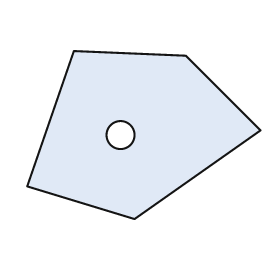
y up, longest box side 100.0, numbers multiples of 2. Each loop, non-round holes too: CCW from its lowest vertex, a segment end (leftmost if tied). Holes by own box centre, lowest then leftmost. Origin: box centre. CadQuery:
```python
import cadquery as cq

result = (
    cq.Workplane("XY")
    .moveTo(-4.0, -36.0)
    .lineTo(50.0, 2.0)
    .lineTo(18.0, 34.0)
    .lineTo(-30.0, 36.0)
    .lineTo(-50.0, -22.0)
    .close()
    .moveTo(-10.0, 0.0)
    .circle(6.0)
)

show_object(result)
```